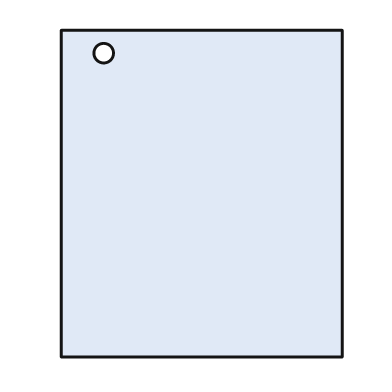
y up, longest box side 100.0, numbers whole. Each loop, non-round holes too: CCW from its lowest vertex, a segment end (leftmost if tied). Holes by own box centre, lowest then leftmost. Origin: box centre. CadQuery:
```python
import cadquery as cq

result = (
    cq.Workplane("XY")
    .moveTo(-43.0, -50.0)
    .lineTo(43.0, -50.0)
    .lineTo(43.0, 50.0)
    .lineTo(-43.0, 50.0)
    .close()
    .moveTo(-30.0, 43.0)
    .circle(3.0)
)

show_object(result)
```